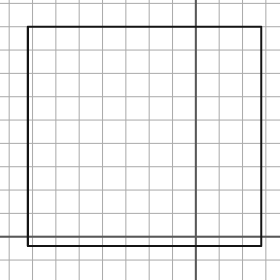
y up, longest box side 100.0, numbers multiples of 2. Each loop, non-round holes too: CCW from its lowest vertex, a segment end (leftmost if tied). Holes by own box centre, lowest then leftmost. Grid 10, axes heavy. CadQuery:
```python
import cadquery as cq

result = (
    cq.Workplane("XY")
    .moveTo(-72.0, -4.0)
    .lineTo(28.0, -4.0)
    .lineTo(28.0, 90.0)
    .lineTo(-72.0, 90.0)
    .close()
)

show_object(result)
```